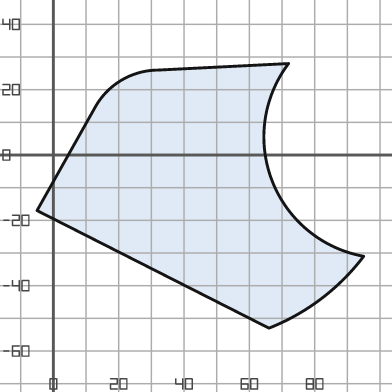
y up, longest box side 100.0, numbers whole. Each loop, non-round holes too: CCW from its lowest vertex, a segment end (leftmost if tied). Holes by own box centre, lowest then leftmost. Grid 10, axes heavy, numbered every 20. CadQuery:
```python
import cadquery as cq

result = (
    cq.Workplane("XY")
    .moveTo(66.0, -53.0)
    .threePointArc((82.0, -44.0), (95.0, -31.0))
    .threePointArc((67.0, -8.0), (72.0, 28.0))
    .lineTo(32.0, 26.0)
    .threePointArc((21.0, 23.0), (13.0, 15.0))
    .lineTo(-5.0, -17.0)
    .close()
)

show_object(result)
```